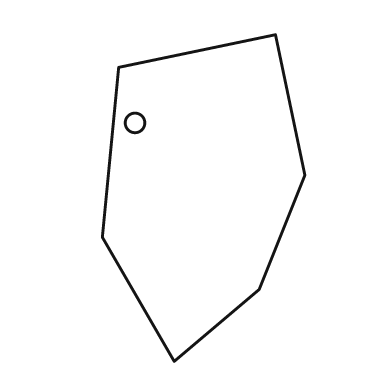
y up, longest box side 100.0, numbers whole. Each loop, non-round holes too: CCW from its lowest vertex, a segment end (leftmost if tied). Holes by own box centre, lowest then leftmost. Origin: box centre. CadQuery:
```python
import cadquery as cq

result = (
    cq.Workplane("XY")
    .moveTo(-9.0, -50.0)
    .lineTo(17.0, -28.0)
    .lineTo(31.0, 7.0)
    .lineTo(22.0, 50.0)
    .lineTo(-26.0, 40.0)
    .lineTo(-31.0, -12.0)
    .close()
    .moveTo(-21.0, 23.0)
    .circle(3.0)
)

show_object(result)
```